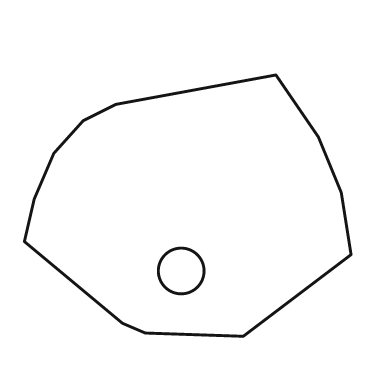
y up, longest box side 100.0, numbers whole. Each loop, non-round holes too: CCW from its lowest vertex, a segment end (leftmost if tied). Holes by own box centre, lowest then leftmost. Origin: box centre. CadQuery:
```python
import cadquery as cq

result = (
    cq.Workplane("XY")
    .moveTo(17.0, -40.0)
    .lineTo(50.0, -15.0)
    .lineTo(47.0, 4.0)
    .lineTo(40.0, 21.0)
    .lineTo(27.0, 40.0)
    .lineTo(-22.0, 31.0)
    .lineTo(-32.0, 26.0)
    .lineTo(-41.0, 16.0)
    .lineTo(-47.0, 2.0)
    .lineTo(-50.0, -11.0)
    .lineTo(-20.0, -36.0)
    .lineTo(-13.0, -39.0)
    .close()
    .moveTo(-2.0, -20.0)
    .circle(7.0)
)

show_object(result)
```